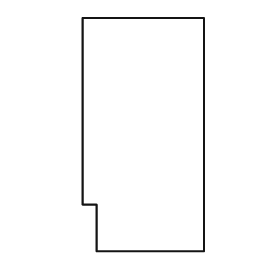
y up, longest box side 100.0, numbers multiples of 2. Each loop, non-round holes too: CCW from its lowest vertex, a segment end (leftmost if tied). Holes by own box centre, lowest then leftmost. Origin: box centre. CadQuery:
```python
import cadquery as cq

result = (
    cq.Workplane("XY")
    .moveTo(-20.0, -50.0)
    .lineTo(26.0, -50.0)
    .lineTo(26.0, 50.0)
    .lineTo(-26.0, 50.0)
    .lineTo(-26.0, -30.0)
    .lineTo(-20.0, -30.0)
    .close()
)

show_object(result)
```